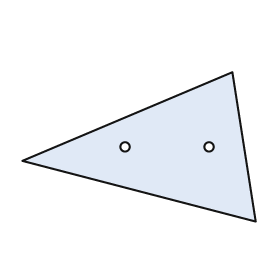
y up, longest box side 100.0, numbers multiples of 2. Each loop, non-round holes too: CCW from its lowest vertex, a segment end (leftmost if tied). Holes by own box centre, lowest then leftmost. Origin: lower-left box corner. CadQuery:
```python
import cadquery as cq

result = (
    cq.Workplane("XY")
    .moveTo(100.0, 0.0)
    .lineTo(90.0, 64.0)
    .lineTo(0.0, 26.0)
    .close()
    .moveTo(44.0, 32.0)
    .circle(2.0)
    .moveTo(80.0, 32.0)
    .circle(2.0)
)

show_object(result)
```